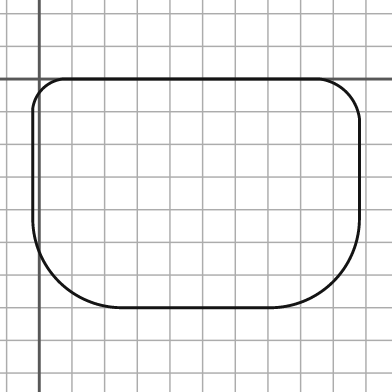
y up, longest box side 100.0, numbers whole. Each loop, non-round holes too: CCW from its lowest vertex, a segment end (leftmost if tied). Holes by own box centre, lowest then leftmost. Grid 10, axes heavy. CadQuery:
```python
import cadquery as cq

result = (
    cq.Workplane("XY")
    .moveTo(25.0, -70.0)
    .lineTo(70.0, -70.0)
    .threePointArc((90.0, -62.0), (98.0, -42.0))
    .lineTo(98.0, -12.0)
    .threePointArc((94.0, -4.0), (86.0, 0.0))
    .lineTo(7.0, 0.0)
    .threePointArc((1.0, -3.0), (-2.0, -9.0))
    .lineTo(-2.0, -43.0)
    .threePointArc((6.0, -62.0), (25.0, -70.0))
    .close()
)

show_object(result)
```